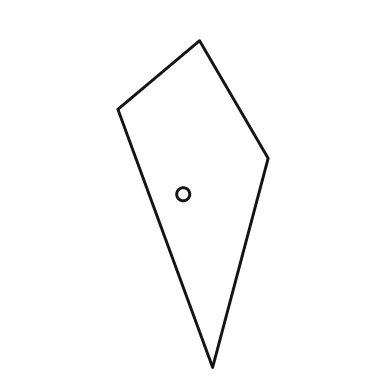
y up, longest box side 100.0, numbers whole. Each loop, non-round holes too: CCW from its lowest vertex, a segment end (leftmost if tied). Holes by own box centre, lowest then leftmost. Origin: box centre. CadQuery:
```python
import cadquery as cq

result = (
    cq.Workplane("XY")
    .moveTo(6.0, -50.0)
    .lineTo(23.0, 14.0)
    .lineTo(2.0, 50.0)
    .lineTo(-23.0, 29.0)
    .close()
    .moveTo(-3.0, 3.0)
    .circle(2.0)
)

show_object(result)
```